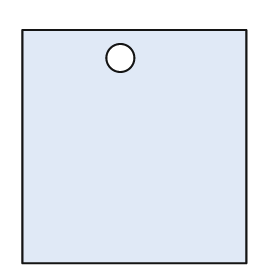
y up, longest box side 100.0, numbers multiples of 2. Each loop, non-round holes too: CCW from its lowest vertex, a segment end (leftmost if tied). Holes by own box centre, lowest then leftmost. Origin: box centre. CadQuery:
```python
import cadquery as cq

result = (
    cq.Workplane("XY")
    .moveTo(-48.0, -50.0)
    .lineTo(48.0, -50.0)
    .lineTo(48.0, 50.0)
    .lineTo(-48.0, 50.0)
    .close()
    .moveTo(-6.0, 38.0)
    .circle(6.0)
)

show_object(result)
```